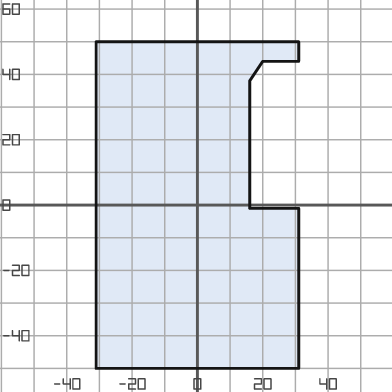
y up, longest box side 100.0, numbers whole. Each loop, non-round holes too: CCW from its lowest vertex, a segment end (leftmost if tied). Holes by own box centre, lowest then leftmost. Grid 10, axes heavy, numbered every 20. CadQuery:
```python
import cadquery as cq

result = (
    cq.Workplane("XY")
    .moveTo(-31.0, -50.0)
    .lineTo(31.0, -50.0)
    .lineTo(31.0, -1.0)
    .lineTo(16.0, -1.0)
    .lineTo(16.0, 38.0)
    .lineTo(20.0, 44.0)
    .lineTo(31.0, 44.0)
    .lineTo(31.0, 50.0)
    .lineTo(-31.0, 50.0)
    .close()
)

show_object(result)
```